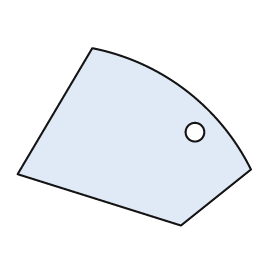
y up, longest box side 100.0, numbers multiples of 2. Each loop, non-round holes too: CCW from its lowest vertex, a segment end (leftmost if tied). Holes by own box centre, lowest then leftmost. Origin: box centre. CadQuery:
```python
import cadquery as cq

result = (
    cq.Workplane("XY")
    .moveTo(20.0, -38.0)
    .lineTo(50.0, -14.0)
    .threePointArc((22.0, 20.0), (-18.0, 38.0))
    .lineTo(-50.0, -16.0)
    .close()
    .moveTo(26.0, 2.0)
    .circle(4.0)
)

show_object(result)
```